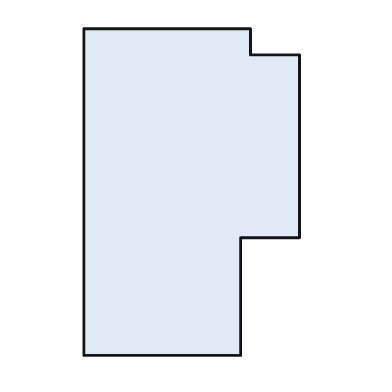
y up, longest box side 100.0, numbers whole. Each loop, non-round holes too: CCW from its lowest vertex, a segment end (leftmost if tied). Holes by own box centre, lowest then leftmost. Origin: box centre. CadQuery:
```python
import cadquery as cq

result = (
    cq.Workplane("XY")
    .moveTo(-33.0, -50.0)
    .lineTo(15.0, -50.0)
    .lineTo(15.0, -14.0)
    .lineTo(33.0, -14.0)
    .lineTo(33.0, 42.0)
    .lineTo(18.0, 42.0)
    .lineTo(18.0, 50.0)
    .lineTo(-33.0, 50.0)
    .close()
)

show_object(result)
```